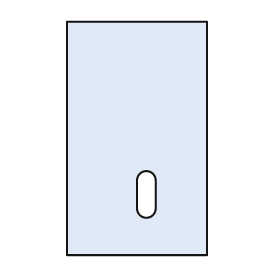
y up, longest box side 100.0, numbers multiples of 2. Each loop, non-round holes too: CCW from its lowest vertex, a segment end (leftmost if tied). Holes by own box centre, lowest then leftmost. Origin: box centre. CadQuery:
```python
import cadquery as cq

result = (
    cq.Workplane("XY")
    .moveTo(-30.0, -50.0)
    .lineTo(30.0, -50.0)
    .lineTo(30.0, 50.0)
    .lineTo(-30.0, 50.0)
    .close()
    .moveTo(0.0, -30.0)
    .threePointArc((4.0, -34.0), (8.0, -30.0))
    .lineTo(8.0, -18.0)
    .threePointArc((4.0, -14.0), (0.0, -18.0))
    .close()
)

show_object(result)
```